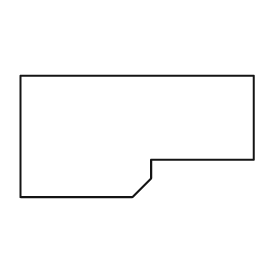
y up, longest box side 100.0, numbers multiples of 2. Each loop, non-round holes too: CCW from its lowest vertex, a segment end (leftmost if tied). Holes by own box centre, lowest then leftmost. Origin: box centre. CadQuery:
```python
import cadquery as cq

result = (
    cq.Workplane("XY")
    .moveTo(-50.0, -26.0)
    .lineTo(-2.0, -26.0)
    .lineTo(6.0, -18.0)
    .lineTo(6.0, -10.0)
    .lineTo(50.0, -10.0)
    .lineTo(50.0, 26.0)
    .lineTo(-50.0, 26.0)
    .close()
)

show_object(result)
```